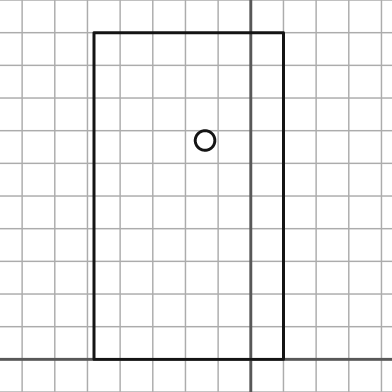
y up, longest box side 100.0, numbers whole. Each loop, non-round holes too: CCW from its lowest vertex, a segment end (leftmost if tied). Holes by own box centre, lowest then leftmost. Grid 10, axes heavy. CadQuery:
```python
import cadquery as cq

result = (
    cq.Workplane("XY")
    .moveTo(-48.0, 0.0)
    .lineTo(10.0, 0.0)
    .lineTo(10.0, 100.0)
    .lineTo(-48.0, 100.0)
    .close()
    .moveTo(-14.0, 67.0)
    .circle(3.0)
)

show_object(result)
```